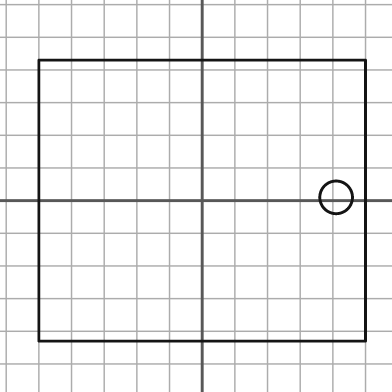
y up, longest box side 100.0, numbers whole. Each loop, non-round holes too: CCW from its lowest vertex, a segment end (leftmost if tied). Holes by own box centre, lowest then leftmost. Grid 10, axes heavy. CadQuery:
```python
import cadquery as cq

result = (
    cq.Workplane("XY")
    .moveTo(-50.0, -43.0)
    .lineTo(50.0, -43.0)
    .lineTo(50.0, 43.0)
    .lineTo(-50.0, 43.0)
    .close()
    .moveTo(41.0, 1.0)
    .circle(5.0)
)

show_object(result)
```